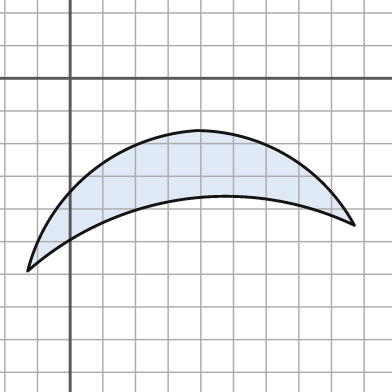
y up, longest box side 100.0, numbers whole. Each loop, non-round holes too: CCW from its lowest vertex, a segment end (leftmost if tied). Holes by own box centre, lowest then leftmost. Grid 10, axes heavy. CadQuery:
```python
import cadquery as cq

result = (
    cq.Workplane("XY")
    .moveTo(-13.0, -59.0)
    .threePointArc((35.0, -37.0), (87.0, -45.0))
    .threePointArc((67.0, -24.0), (39.0, -16.0))
    .threePointArc((6.0, -29.0), (-13.0, -59.0))
    .close()
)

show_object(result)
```